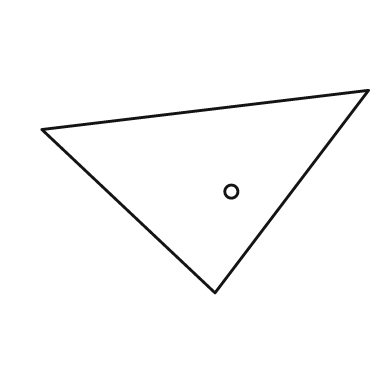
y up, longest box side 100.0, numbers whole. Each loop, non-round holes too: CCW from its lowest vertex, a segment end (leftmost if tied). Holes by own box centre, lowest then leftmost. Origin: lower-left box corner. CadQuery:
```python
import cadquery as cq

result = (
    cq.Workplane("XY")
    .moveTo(53.0, 0.0)
    .lineTo(100.0, 62.0)
    .lineTo(0.0, 50.0)
    .close()
    .moveTo(58.0, 31.0)
    .circle(2.0)
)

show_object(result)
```